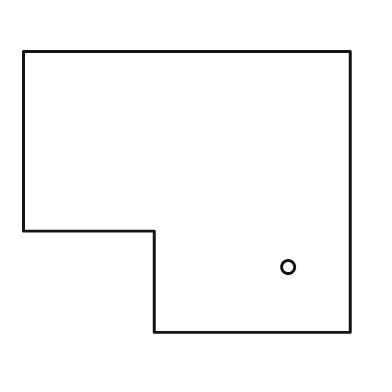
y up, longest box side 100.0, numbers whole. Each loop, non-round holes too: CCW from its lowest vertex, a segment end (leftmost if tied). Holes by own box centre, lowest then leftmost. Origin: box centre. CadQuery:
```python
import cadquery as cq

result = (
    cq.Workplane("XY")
    .moveTo(-10.0, -43.0)
    .lineTo(50.0, -43.0)
    .lineTo(50.0, 43.0)
    .lineTo(-50.0, 43.0)
    .lineTo(-50.0, -12.0)
    .lineTo(-10.0, -12.0)
    .close()
    .moveTo(31.0, -23.0)
    .circle(2.0)
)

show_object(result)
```